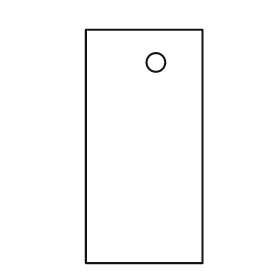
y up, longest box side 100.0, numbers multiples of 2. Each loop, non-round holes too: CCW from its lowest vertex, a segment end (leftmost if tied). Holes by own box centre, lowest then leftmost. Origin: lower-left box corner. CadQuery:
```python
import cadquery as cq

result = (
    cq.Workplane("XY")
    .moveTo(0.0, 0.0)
    .lineTo(50.0, 0.0)
    .lineTo(50.0, 100.0)
    .lineTo(0.0, 100.0)
    .close()
    .moveTo(30.0, 86.0)
    .circle(4.0)
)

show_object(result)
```